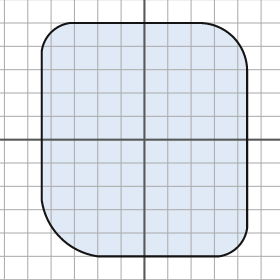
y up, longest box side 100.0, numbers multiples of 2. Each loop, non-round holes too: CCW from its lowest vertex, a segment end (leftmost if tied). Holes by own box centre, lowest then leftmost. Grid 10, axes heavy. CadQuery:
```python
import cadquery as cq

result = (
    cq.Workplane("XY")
    .moveTo(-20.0, -50.0)
    .lineTo(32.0, -50.0)
    .threePointArc((40.0, -46.0), (44.0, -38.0))
    .lineTo(44.0, 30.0)
    .threePointArc((38.0, 44.0), (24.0, 50.0))
    .lineTo(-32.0, 50.0)
    .threePointArc((-40.0, 46.0), (-44.0, 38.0))
    .lineTo(-44.0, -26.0)
    .threePointArc((-36.0, -42.0), (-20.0, -50.0))
    .close()
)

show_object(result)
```